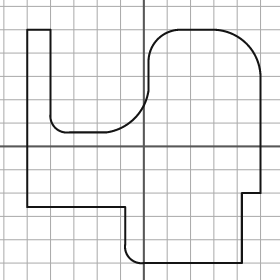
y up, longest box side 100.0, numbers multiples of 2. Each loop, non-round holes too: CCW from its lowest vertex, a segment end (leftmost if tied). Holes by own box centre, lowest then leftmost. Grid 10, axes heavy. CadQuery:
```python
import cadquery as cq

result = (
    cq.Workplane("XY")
    .moveTo(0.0, -50.0)
    .lineTo(42.0, -50.0)
    .lineTo(42.0, -20.0)
    .lineTo(50.0, -20.0)
    .lineTo(50.0, 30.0)
    .threePointArc((44.0, 44.0), (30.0, 50.0))
    .lineTo(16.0, 50.0)
    .threePointArc((6.0, 46.0), (2.0, 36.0))
    .lineTo(2.0, 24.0)
    .threePointArc((-4.0, 12.0), (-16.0, 6.0))
    .lineTo(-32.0, 6.0)
    .threePointArc((-38.0, 8.0), (-40.0, 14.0))
    .lineTo(-40.0, 50.0)
    .lineTo(-50.0, 50.0)
    .lineTo(-50.0, -26.0)
    .lineTo(-8.0, -26.0)
    .lineTo(-8.0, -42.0)
    .threePointArc((-6.0, -48.0), (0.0, -50.0))
    .close()
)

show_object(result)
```